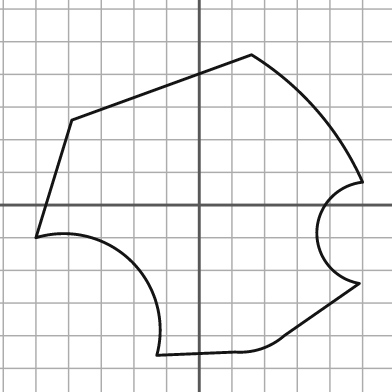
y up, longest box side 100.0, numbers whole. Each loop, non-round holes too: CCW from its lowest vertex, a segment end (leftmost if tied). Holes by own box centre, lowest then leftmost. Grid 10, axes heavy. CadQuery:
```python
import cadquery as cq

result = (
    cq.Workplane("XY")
    .moveTo(-13.0, -46.0)
    .lineTo(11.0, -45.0)
    .threePointArc((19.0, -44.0), (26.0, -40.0))
    .lineTo(49.0, -24.0)
    .threePointArc((36.0, -8.0), (50.0, 7.0))
    .threePointArc((36.0, 29.0), (16.0, 46.0))
    .lineTo(-39.0, 26.0)
    .lineTo(-50.0, -10.0)
    .threePointArc((-21.0, -17.0), (-13.0, -46.0))
    .close()
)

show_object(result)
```